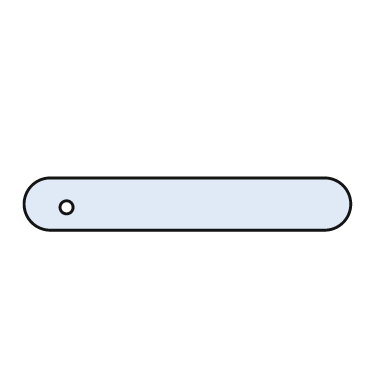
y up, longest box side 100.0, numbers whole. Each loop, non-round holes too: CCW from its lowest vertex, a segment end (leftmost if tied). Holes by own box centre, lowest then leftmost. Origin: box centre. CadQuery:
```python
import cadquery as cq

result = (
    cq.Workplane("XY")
    .moveTo(-42.0, -8.0)
    .lineTo(42.0, -8.0)
    .threePointArc((50.0, 0.0), (42.0, 8.0))
    .lineTo(-42.0, 8.0)
    .threePointArc((-50.0, 0.0), (-42.0, -8.0))
    .close()
    .moveTo(-37.0, -1.0)
    .circle(2.0)
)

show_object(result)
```